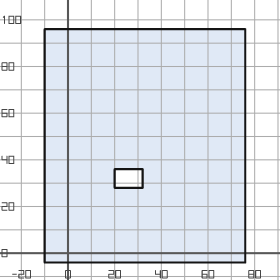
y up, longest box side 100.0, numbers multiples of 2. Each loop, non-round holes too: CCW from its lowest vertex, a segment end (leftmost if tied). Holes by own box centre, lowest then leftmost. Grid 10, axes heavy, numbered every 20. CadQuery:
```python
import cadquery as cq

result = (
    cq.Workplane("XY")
    .moveTo(-10.0, -4.0)
    .lineTo(76.0, -4.0)
    .lineTo(76.0, 96.0)
    .lineTo(-10.0, 96.0)
    .close()
    .moveTo(20.0, 28.0)
    .lineTo(32.0, 28.0)
    .lineTo(32.0, 36.0)
    .lineTo(20.0, 36.0)
    .close()
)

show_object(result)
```